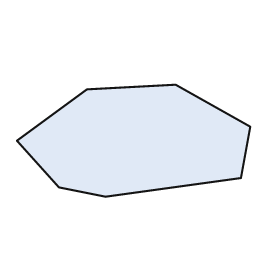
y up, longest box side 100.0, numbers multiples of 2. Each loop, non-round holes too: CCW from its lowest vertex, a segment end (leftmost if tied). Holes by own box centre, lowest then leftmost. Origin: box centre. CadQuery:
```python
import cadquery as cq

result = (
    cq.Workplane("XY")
    .moveTo(-12.0, -24.0)
    .lineTo(46.0, -16.0)
    .lineTo(50.0, 6.0)
    .lineTo(18.0, 24.0)
    .lineTo(-20.0, 22.0)
    .lineTo(-50.0, 0.0)
    .lineTo(-32.0, -20.0)
    .close()
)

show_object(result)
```